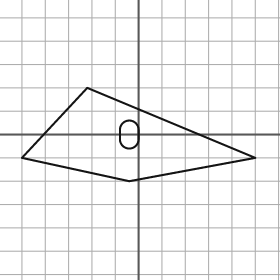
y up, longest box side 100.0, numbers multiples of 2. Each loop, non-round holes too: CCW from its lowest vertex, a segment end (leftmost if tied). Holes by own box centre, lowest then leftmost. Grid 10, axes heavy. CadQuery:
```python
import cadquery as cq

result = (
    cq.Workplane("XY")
    .moveTo(-4.0, -20.0)
    .lineTo(50.0, -10.0)
    .lineTo(-22.0, 20.0)
    .lineTo(-50.0, -10.0)
    .close()
    .moveTo(-8.0, -2.0)
    .threePointArc((-4.0, -6.0), (0.0, -2.0))
    .lineTo(0.0, 2.0)
    .threePointArc((-4.0, 6.0), (-8.0, 2.0))
    .close()
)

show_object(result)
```